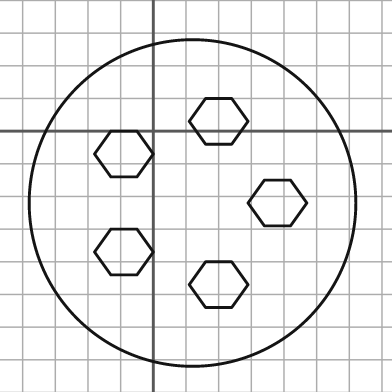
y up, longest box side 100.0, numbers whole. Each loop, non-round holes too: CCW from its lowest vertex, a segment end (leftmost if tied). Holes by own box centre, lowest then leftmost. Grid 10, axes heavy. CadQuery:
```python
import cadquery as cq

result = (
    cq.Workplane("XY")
    .moveTo(12.0, -22.0)
    .circle(50.0)
    .moveTo(16.0, -54.0)
    .lineTo(24.0, -54.0)
    .lineTo(29.0, -47.0)
    .lineTo(24.0, -40.0)
    .lineTo(16.0, -40.0)
    .lineTo(11.0, -47.0)
    .close()
    .moveTo(-13.0, -44.0)
    .lineTo(-5.0, -44.0)
    .lineTo(0.0, -37.0)
    .lineTo(-5.0, -30.0)
    .lineTo(-13.0, -30.0)
    .lineTo(-18.0, -37.0)
    .close()
    .moveTo(34.0, -29.0)
    .lineTo(42.0, -29.0)
    .lineTo(47.0, -22.0)
    .lineTo(42.0, -15.0)
    .lineTo(34.0, -15.0)
    .lineTo(29.0, -22.0)
    .close()
    .moveTo(-13.0, -14.0)
    .lineTo(-5.0, -14.0)
    .lineTo(0.0, -7.0)
    .lineTo(-5.0, 0.0)
    .lineTo(-13.0, 0.0)
    .lineTo(-18.0, -7.0)
    .close()
    .moveTo(16.0, -4.0)
    .lineTo(24.0, -4.0)
    .lineTo(29.0, 3.0)
    .lineTo(24.0, 10.0)
    .lineTo(16.0, 10.0)
    .lineTo(11.0, 3.0)
    .close()
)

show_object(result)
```